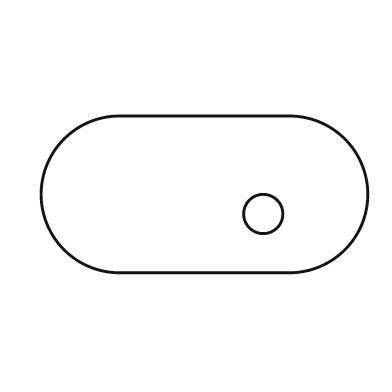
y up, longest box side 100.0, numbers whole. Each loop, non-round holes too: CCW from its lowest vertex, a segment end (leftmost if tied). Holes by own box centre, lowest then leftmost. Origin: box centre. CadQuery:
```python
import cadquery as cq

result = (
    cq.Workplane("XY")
    .moveTo(-26.0, -24.0)
    .lineTo(26.0, -24.0)
    .threePointArc((50.0, 0.0), (26.0, 24.0))
    .lineTo(-26.0, 24.0)
    .threePointArc((-50.0, 0.0), (-26.0, -24.0))
    .close()
    .moveTo(18.0, -6.0)
    .circle(6.0)
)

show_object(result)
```